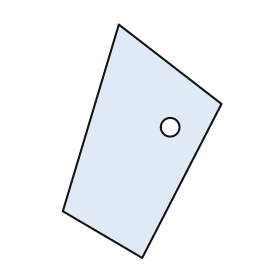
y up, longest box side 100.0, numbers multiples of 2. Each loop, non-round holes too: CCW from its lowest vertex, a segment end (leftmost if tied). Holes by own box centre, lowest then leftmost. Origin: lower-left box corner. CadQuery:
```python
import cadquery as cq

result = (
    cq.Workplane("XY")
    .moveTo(34.0, 0.0)
    .lineTo(68.0, 66.0)
    .lineTo(24.0, 100.0)
    .lineTo(0.0, 20.0)
    .close()
    .moveTo(46.0, 56.0)
    .circle(4.0)
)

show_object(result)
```